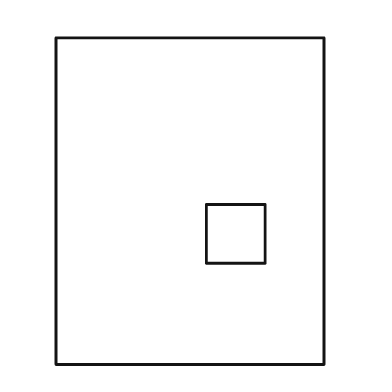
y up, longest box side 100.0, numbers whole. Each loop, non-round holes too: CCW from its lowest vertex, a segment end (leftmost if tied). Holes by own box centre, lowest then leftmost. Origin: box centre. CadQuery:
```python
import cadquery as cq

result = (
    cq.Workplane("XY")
    .moveTo(-41.0, -50.0)
    .lineTo(41.0, -50.0)
    .lineTo(41.0, 50.0)
    .lineTo(-41.0, 50.0)
    .close()
    .moveTo(5.0, -19.0)
    .lineTo(23.0, -19.0)
    .lineTo(23.0, -1.0)
    .lineTo(5.0, -1.0)
    .close()
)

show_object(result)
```